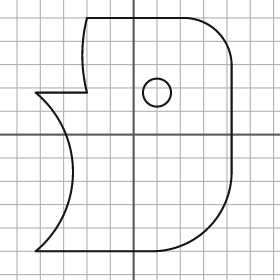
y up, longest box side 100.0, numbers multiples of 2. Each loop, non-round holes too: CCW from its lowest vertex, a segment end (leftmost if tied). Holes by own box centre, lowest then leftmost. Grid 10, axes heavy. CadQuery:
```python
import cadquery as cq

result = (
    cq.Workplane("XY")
    .moveTo(-42.0, -50.0)
    .lineTo(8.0, -50.0)
    .threePointArc((32.0, -40.0), (42.0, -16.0))
    .lineTo(42.0, 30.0)
    .threePointArc((36.0, 44.0), (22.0, 50.0))
    .lineTo(-20.0, 50.0)
    .threePointArc((-22.0, 34.0), (-20.0, 18.0))
    .lineTo(-42.0, 18.0)
    .threePointArc((-26.0, -16.0), (-42.0, -50.0))
    .close()
    .moveTo(10.0, 18.0)
    .circle(6.0)
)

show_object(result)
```